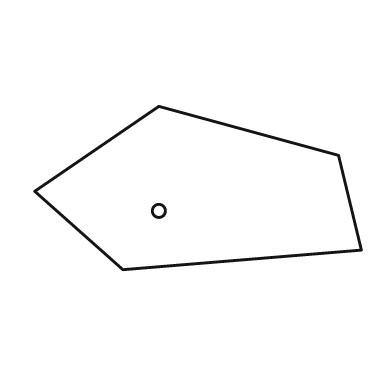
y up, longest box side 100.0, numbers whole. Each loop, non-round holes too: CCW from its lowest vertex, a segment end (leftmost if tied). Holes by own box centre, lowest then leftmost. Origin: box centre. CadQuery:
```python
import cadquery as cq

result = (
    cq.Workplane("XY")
    .moveTo(-23.0, -25.0)
    .lineTo(50.0, -19.0)
    .lineTo(43.0, 10.0)
    .lineTo(-12.0, 25.0)
    .lineTo(-50.0, -1.0)
    .close()
    .moveTo(-12.0, -7.0)
    .circle(2.0)
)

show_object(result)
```